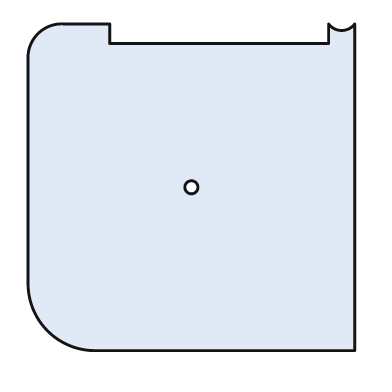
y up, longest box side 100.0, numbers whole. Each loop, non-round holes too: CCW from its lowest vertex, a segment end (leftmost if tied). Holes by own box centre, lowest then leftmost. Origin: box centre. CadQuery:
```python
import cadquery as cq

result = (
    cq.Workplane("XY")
    .moveTo(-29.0, -50.0)
    .lineTo(50.0, -50.0)
    .lineTo(50.0, 50.0)
    .threePointArc((46.0, 48.0), (42.0, 50.0))
    .lineTo(42.0, 44.0)
    .lineTo(-25.0, 44.0)
    .lineTo(-25.0, 50.0)
    .lineTo(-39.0, 50.0)
    .threePointArc((-47.0, 47.0), (-50.0, 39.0))
    .lineTo(-50.0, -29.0)
    .threePointArc((-44.0, -44.0), (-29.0, -50.0))
    .close()
    .moveTo(0.0, 0.0)
    .circle(2.0)
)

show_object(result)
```